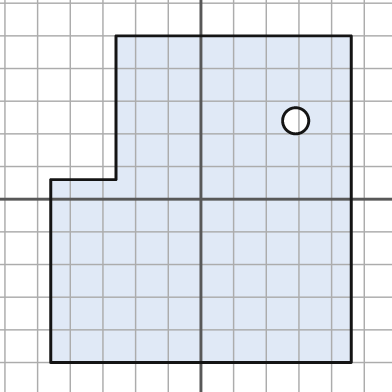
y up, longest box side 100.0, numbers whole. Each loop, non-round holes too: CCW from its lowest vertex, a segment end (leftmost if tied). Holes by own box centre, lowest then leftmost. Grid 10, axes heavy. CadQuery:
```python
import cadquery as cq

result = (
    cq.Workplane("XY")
    .moveTo(-46.0, -50.0)
    .lineTo(46.0, -50.0)
    .lineTo(46.0, 50.0)
    .lineTo(-26.0, 50.0)
    .lineTo(-26.0, 6.0)
    .lineTo(-46.0, 6.0)
    .close()
    .moveTo(29.0, 24.0)
    .circle(4.0)
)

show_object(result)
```